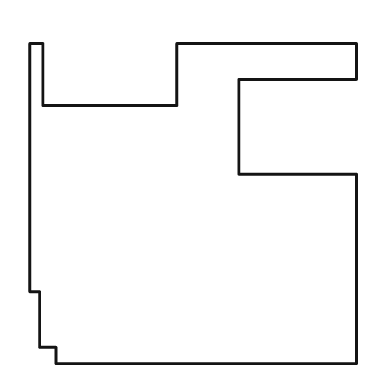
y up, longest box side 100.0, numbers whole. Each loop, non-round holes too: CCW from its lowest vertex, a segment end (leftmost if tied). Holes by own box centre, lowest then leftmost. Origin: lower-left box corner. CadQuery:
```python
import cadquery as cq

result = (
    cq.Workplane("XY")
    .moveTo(8.0, 0.0)
    .lineTo(100.0, 0.0)
    .lineTo(100.0, 58.0)
    .lineTo(64.0, 58.0)
    .lineTo(64.0, 87.0)
    .lineTo(100.0, 87.0)
    .lineTo(100.0, 98.0)
    .lineTo(45.0, 98.0)
    .lineTo(45.0, 79.0)
    .lineTo(4.0, 79.0)
    .lineTo(4.0, 98.0)
    .lineTo(0.0, 98.0)
    .lineTo(0.0, 22.0)
    .lineTo(3.0, 22.0)
    .lineTo(3.0, 5.0)
    .lineTo(8.0, 5.0)
    .close()
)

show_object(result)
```